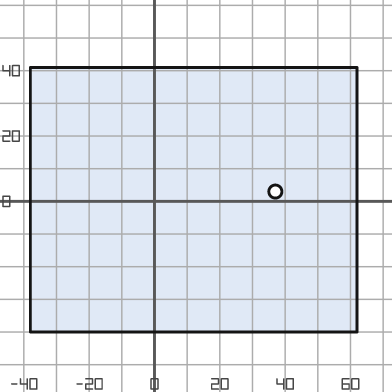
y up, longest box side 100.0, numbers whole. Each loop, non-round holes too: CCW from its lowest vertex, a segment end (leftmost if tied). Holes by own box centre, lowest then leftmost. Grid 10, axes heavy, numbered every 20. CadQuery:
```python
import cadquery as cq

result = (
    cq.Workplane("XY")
    .moveTo(-38.0, -40.0)
    .lineTo(62.0, -40.0)
    .lineTo(62.0, 41.0)
    .lineTo(-38.0, 41.0)
    .close()
    .moveTo(37.0, 3.0)
    .circle(2.0)
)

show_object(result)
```